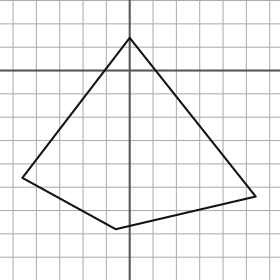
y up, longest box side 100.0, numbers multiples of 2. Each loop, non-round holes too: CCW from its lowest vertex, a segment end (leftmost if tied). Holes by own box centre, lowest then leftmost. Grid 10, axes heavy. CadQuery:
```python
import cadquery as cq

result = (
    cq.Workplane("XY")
    .moveTo(-6.0, -68.0)
    .lineTo(54.0, -54.0)
    .lineTo(0.0, 14.0)
    .lineTo(-46.0, -46.0)
    .close()
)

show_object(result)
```